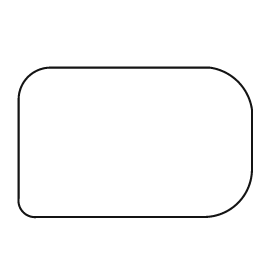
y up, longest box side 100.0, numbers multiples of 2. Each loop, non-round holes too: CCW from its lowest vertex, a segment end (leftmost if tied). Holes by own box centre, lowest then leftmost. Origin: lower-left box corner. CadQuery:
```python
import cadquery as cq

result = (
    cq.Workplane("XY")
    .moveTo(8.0, 0.0)
    .lineTo(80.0, 0.0)
    .threePointArc((94.0, 6.0), (100.0, 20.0))
    .lineTo(100.0, 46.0)
    .threePointArc((94.0, 58.0), (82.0, 64.0))
    .lineTo(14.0, 64.0)
    .threePointArc((4.0, 60.0), (0.0, 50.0))
    .lineTo(0.0, 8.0)
    .threePointArc((2.0, 2.0), (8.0, 0.0))
    .close()
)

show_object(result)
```